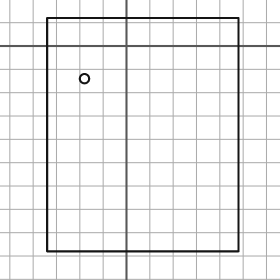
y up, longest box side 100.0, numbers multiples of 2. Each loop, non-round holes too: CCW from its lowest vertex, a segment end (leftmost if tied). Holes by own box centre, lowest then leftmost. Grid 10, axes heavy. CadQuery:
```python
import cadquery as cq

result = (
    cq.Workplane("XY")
    .moveTo(-34.0, -88.0)
    .lineTo(48.0, -88.0)
    .lineTo(48.0, 12.0)
    .lineTo(-34.0, 12.0)
    .close()
    .moveTo(-18.0, -14.0)
    .circle(2.0)
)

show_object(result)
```